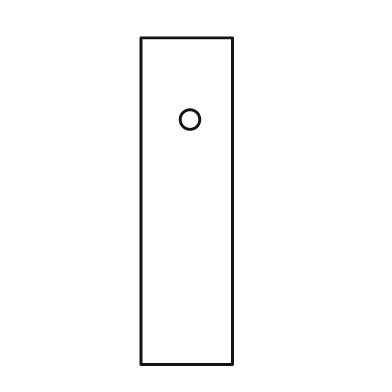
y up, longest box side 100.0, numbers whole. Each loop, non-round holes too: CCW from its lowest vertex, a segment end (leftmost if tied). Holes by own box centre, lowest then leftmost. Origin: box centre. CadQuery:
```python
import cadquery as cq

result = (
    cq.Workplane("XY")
    .moveTo(-14.0, -50.0)
    .lineTo(14.0, -50.0)
    .lineTo(14.0, 50.0)
    .lineTo(-14.0, 50.0)
    .close()
    .moveTo(1.0, 25.0)
    .circle(3.0)
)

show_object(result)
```